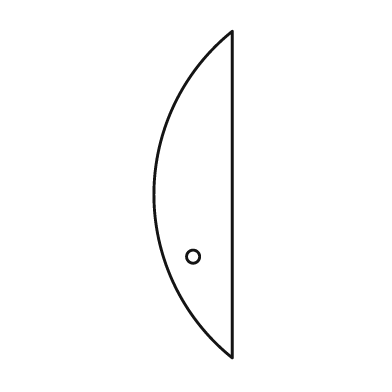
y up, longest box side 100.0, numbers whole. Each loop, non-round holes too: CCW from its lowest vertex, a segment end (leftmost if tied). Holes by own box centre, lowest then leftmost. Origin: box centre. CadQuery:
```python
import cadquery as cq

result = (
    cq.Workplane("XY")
    .moveTo(12.0, -50.0)
    .lineTo(12.0, 50.0)
    .threePointArc((-12.0, 0.0), (12.0, -50.0))
    .close()
    .moveTo(0.0, -19.0)
    .circle(2.0)
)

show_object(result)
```